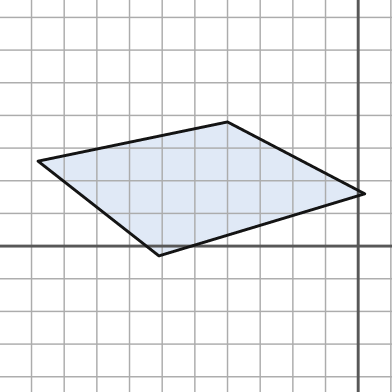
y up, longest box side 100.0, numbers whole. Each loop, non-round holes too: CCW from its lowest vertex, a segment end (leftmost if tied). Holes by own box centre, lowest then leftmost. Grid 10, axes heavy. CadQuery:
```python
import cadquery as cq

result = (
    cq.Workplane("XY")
    .moveTo(-61.0, -3.0)
    .lineTo(2.0, 16.0)
    .lineTo(-40.0, 38.0)
    .lineTo(-98.0, 26.0)
    .close()
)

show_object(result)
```